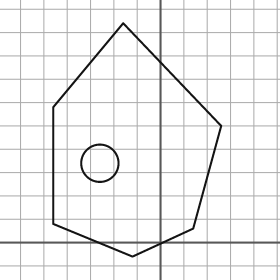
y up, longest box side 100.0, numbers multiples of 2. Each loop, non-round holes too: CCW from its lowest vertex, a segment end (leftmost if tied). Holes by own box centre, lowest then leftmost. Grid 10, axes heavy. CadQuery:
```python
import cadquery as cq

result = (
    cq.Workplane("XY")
    .moveTo(-12.0, -6.0)
    .lineTo(14.0, 6.0)
    .lineTo(26.0, 50.0)
    .lineTo(-16.0, 94.0)
    .lineTo(-46.0, 58.0)
    .lineTo(-46.0, 8.0)
    .close()
    .moveTo(-26.0, 34.0)
    .circle(8.0)
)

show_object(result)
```